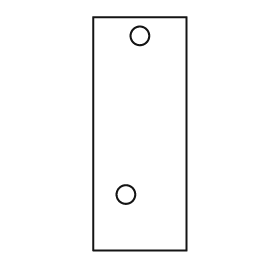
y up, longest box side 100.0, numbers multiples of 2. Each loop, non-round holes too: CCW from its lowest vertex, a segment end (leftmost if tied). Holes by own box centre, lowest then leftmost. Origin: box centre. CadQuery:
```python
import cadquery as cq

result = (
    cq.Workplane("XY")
    .moveTo(-20.0, -50.0)
    .lineTo(20.0, -50.0)
    .lineTo(20.0, 50.0)
    .lineTo(-20.0, 50.0)
    .close()
    .moveTo(-6.0, -26.0)
    .circle(4.0)
    .moveTo(0.0, 42.0)
    .circle(4.0)
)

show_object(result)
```